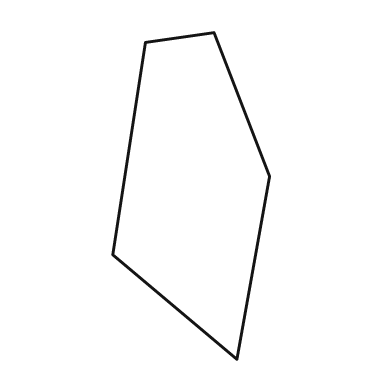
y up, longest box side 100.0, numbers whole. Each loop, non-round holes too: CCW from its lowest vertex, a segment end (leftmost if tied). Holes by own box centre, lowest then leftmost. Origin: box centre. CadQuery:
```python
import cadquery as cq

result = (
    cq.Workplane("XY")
    .moveTo(14.0, -50.0)
    .lineTo(24.0, 6.0)
    .lineTo(7.0, 50.0)
    .lineTo(-14.0, 47.0)
    .lineTo(-24.0, -18.0)
    .close()
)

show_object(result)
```